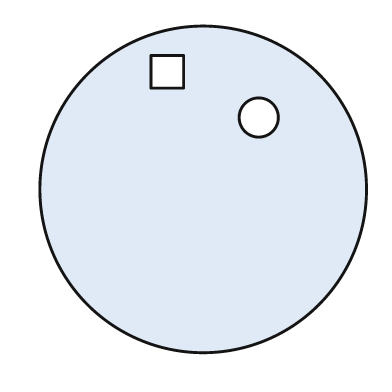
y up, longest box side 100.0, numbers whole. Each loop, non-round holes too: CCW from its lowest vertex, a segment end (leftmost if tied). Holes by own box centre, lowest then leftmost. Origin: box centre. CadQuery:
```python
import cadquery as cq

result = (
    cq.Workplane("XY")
    .moveTo(0.0, 0.0)
    .circle(50.0)
    .moveTo(17.0, 22.0)
    .circle(6.0)
    .moveTo(-16.0, 31.0)
    .lineTo(-6.0, 31.0)
    .lineTo(-6.0, 41.0)
    .lineTo(-16.0, 41.0)
    .close()
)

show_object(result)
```